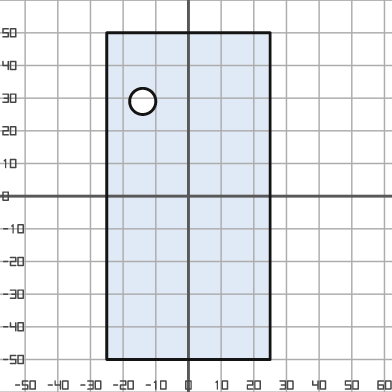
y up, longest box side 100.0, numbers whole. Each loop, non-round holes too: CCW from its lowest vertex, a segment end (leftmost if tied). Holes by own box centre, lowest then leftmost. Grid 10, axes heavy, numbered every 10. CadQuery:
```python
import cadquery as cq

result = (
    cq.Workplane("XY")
    .moveTo(-25.0, -50.0)
    .lineTo(25.0, -50.0)
    .lineTo(25.0, 50.0)
    .lineTo(-25.0, 50.0)
    .close()
    .moveTo(-14.0, 29.0)
    .circle(4.0)
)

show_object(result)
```